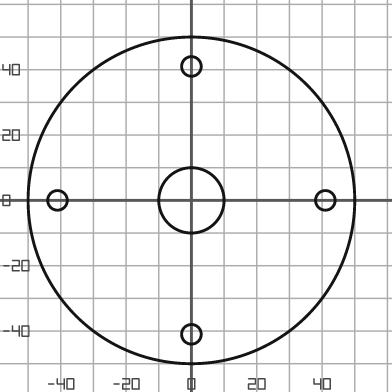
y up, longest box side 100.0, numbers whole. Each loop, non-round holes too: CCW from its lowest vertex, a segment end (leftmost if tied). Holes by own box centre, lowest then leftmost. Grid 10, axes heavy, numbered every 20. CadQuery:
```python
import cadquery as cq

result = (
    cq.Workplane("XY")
    .moveTo(0.0, 0.0)
    .circle(50.0)
    .moveTo(0.0, -41.0)
    .circle(3.0)
    .moveTo(-41.0, 0.0)
    .circle(3.0)
    .moveTo(0.0, 0.0)
    .circle(10.0)
    .moveTo(41.0, 0.0)
    .circle(3.0)
    .moveTo(0.0, 41.0)
    .circle(3.0)
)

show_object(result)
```